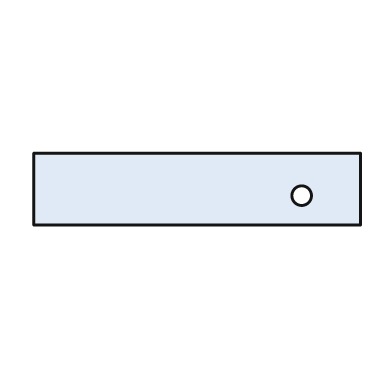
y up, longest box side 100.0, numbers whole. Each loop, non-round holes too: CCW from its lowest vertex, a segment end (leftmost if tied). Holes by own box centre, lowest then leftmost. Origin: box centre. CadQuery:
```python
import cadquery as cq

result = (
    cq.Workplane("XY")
    .moveTo(-50.0, -11.0)
    .lineTo(50.0, -11.0)
    .lineTo(50.0, 11.0)
    .lineTo(-50.0, 11.0)
    .close()
    .moveTo(32.0, -2.0)
    .circle(3.0)
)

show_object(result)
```